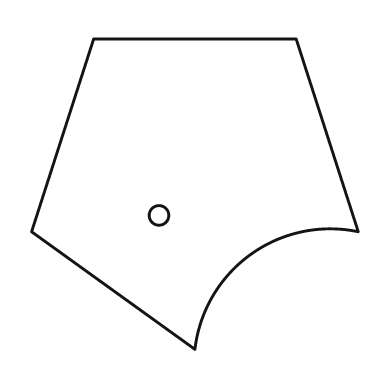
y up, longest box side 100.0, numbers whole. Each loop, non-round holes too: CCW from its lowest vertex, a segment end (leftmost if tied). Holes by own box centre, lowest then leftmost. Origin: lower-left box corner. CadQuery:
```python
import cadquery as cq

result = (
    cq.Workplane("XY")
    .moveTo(50.0, 0.0)
    .threePointArc((67.0, 29.0), (100.0, 36.0))
    .lineTo(81.0, 95.0)
    .lineTo(19.0, 95.0)
    .lineTo(0.0, 36.0)
    .close()
    .moveTo(39.0, 41.0)
    .circle(3.0)
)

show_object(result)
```